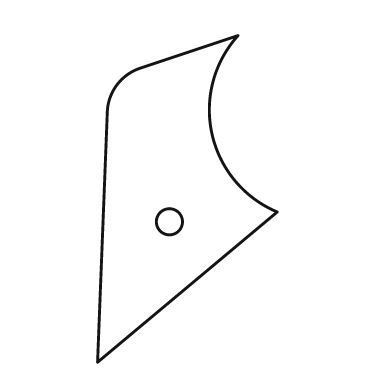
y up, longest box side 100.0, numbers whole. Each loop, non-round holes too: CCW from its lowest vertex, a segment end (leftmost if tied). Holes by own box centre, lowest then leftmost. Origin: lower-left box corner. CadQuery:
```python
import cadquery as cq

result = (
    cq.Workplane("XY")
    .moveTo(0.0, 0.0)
    .lineTo(55.0, 46.0)
    .threePointArc((35.0, 70.0), (43.0, 100.0))
    .lineTo(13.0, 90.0)
    .threePointArc((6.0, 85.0), (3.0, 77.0))
    .close()
    .moveTo(22.0, 43.0)
    .circle(4.0)
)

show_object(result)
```